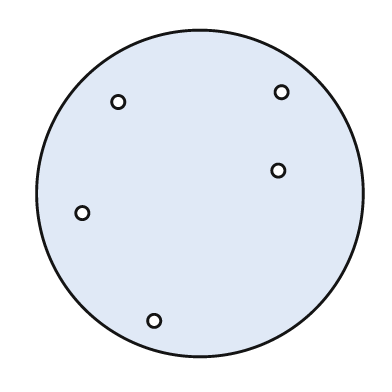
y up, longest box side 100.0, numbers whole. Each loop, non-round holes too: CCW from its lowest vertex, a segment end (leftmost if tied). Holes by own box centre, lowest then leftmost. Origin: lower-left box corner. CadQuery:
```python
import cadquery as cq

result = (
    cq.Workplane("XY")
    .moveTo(50.0, 50.0)
    .circle(50.0)
    .moveTo(36.0, 11.0)
    .circle(2.0)
    .moveTo(14.0, 44.0)
    .circle(2.0)
    .moveTo(74.0, 57.0)
    .circle(2.0)
    .moveTo(25.0, 78.0)
    .circle(2.0)
    .moveTo(75.0, 81.0)
    .circle(2.0)
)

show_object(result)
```